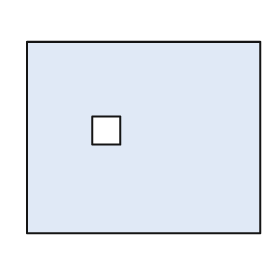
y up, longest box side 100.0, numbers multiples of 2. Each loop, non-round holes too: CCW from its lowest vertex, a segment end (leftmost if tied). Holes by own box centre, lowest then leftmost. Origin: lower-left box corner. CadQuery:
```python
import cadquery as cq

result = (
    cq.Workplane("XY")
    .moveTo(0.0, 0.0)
    .lineTo(100.0, 0.0)
    .lineTo(100.0, 82.0)
    .lineTo(0.0, 82.0)
    .close()
    .moveTo(28.0, 38.0)
    .lineTo(40.0, 38.0)
    .lineTo(40.0, 50.0)
    .lineTo(28.0, 50.0)
    .close()
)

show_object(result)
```